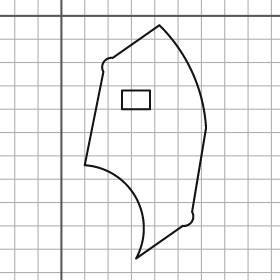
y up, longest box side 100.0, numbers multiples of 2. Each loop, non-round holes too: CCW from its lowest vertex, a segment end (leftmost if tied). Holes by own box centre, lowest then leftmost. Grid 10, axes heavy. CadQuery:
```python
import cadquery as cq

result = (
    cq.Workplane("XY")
    .moveTo(32.0, -104.0)
    .lineTo(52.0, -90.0)
    .threePointArc((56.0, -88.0), (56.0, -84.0))
    .lineTo(62.0, -48.0)
    .threePointArc((56.0, -24.0), (42.0, -4.0))
    .lineTo(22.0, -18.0)
    .threePointArc((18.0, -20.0), (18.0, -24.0))
    .lineTo(10.0, -64.0)
    .threePointArc((32.0, -78.0), (32.0, -104.0))
    .close()
    .moveTo(26.0, -40.0)
    .lineTo(38.0, -40.0)
    .lineTo(38.0, -32.0)
    .lineTo(26.0, -32.0)
    .close()
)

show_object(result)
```